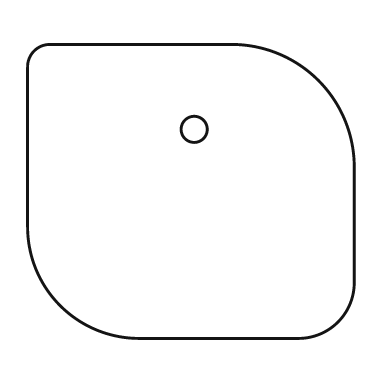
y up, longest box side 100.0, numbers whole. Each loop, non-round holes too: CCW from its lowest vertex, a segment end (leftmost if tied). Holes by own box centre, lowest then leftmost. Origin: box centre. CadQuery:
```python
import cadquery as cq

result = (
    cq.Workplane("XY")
    .moveTo(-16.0, -45.0)
    .lineTo(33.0, -45.0)
    .threePointArc((45.0, -40.0), (50.0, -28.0))
    .lineTo(50.0, 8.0)
    .threePointArc((39.0, 34.0), (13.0, 45.0))
    .lineTo(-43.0, 45.0)
    .threePointArc((-48.0, 43.0), (-50.0, 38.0))
    .lineTo(-50.0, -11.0)
    .threePointArc((-40.0, -35.0), (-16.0, -45.0))
    .close()
    .moveTo(1.0, 19.0)
    .circle(4.0)
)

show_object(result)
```